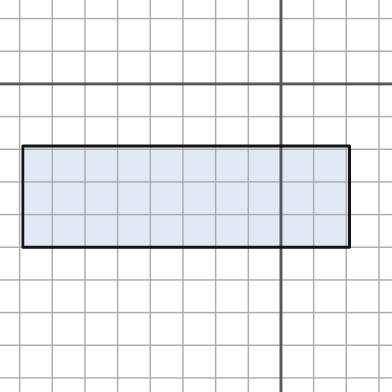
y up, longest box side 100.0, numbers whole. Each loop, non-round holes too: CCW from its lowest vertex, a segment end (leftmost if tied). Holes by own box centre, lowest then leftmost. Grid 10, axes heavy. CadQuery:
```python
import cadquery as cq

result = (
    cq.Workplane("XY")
    .moveTo(-79.0, -50.0)
    .lineTo(21.0, -50.0)
    .lineTo(21.0, -19.0)
    .lineTo(-79.0, -19.0)
    .close()
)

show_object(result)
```